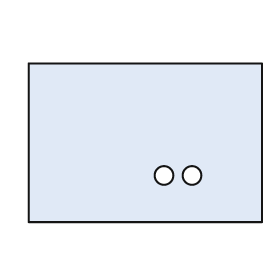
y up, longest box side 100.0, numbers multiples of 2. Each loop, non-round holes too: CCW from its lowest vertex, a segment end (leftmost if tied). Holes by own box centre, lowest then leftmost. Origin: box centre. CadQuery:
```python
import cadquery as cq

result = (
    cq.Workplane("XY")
    .moveTo(-50.0, -34.0)
    .lineTo(50.0, -34.0)
    .lineTo(50.0, 34.0)
    .lineTo(-50.0, 34.0)
    .close()
    .moveTo(8.0, -14.0)
    .circle(4.0)
    .moveTo(20.0, -14.0)
    .circle(4.0)
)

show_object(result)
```